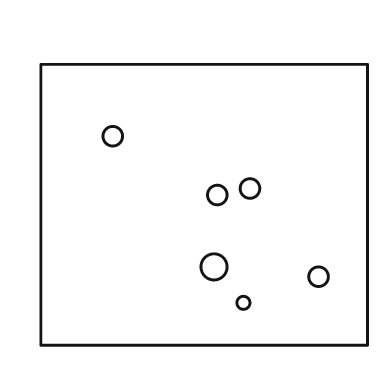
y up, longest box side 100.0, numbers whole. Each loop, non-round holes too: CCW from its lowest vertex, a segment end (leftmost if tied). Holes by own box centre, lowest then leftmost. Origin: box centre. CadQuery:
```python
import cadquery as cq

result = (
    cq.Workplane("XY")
    .moveTo(-50.0, -43.0)
    .lineTo(50.0, -43.0)
    .lineTo(50.0, 43.0)
    .lineTo(-50.0, 43.0)
    .close()
    .moveTo(12.0, -30.0)
    .circle(2.0)
    .moveTo(35.0, -22.0)
    .circle(3.0)
    .moveTo(3.0, -19.0)
    .circle(4.0)
    .moveTo(4.0, 3.0)
    .circle(3.0)
    .moveTo(14.0, 5.0)
    .circle(3.0)
    .moveTo(-28.0, 21.0)
    .circle(3.0)
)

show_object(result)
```